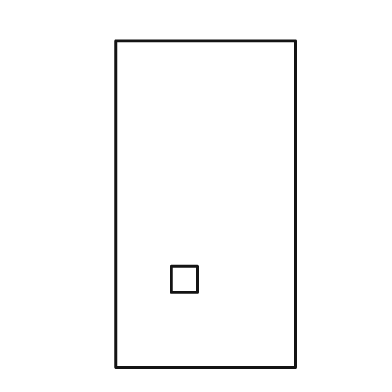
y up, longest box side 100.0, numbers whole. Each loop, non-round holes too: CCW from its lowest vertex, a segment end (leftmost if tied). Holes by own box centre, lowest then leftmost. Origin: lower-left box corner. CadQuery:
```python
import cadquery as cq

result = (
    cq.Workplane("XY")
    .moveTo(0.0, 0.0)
    .lineTo(55.0, 0.0)
    .lineTo(55.0, 100.0)
    .lineTo(0.0, 100.0)
    .close()
    .moveTo(17.0, 23.0)
    .lineTo(25.0, 23.0)
    .lineTo(25.0, 31.0)
    .lineTo(17.0, 31.0)
    .close()
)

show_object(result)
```